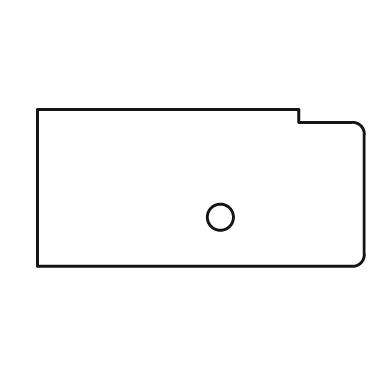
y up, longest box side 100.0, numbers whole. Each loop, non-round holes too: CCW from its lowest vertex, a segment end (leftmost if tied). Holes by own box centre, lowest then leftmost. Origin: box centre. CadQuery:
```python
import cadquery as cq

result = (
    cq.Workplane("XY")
    .moveTo(-50.0, -24.0)
    .lineTo(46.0, -24.0)
    .threePointArc((49.0, -23.0), (50.0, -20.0))
    .lineTo(50.0, 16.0)
    .threePointArc((49.0, 19.0), (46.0, 20.0))
    .lineTo(30.0, 20.0)
    .lineTo(30.0, 24.0)
    .lineTo(-50.0, 24.0)
    .close()
    .moveTo(6.0, -9.0)
    .circle(4.0)
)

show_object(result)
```